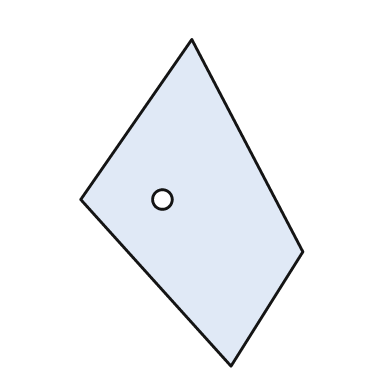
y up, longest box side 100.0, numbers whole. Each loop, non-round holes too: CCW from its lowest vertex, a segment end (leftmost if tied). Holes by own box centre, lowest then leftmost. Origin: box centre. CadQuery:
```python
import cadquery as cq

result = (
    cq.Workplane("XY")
    .moveTo(12.0, -50.0)
    .lineTo(34.0, -15.0)
    .lineTo(0.0, 50.0)
    .lineTo(-34.0, 1.0)
    .close()
    .moveTo(-9.0, 1.0)
    .circle(3.0)
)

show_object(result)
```